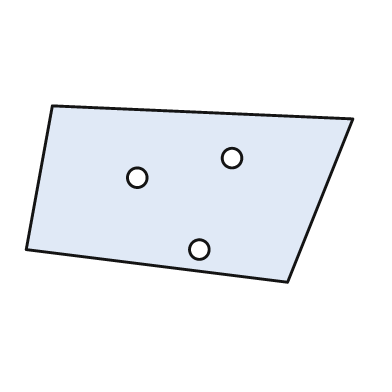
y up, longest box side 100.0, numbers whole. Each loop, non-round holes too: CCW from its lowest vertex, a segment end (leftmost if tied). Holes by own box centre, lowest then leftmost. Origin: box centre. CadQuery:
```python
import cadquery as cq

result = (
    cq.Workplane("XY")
    .moveTo(30.0, -27.0)
    .lineTo(50.0, 23.0)
    .lineTo(-42.0, 27.0)
    .lineTo(-50.0, -17.0)
    .close()
    .moveTo(3.0, -17.0)
    .circle(3.0)
    .moveTo(-16.0, 5.0)
    .circle(3.0)
    .moveTo(13.0, 11.0)
    .circle(3.0)
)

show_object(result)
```